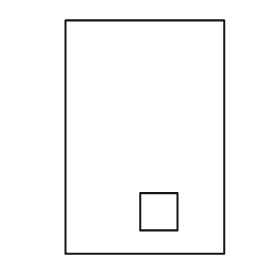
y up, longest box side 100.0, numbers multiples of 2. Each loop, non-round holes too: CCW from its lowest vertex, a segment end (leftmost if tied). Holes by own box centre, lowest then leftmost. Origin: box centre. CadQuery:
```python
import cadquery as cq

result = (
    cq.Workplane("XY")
    .moveTo(-34.0, -50.0)
    .lineTo(34.0, -50.0)
    .lineTo(34.0, 50.0)
    .lineTo(-34.0, 50.0)
    .close()
    .moveTo(-2.0, -40.0)
    .lineTo(14.0, -40.0)
    .lineTo(14.0, -24.0)
    .lineTo(-2.0, -24.0)
    .close()
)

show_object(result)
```